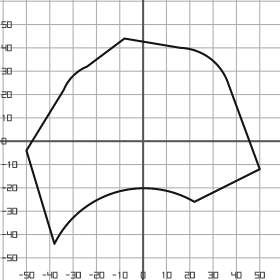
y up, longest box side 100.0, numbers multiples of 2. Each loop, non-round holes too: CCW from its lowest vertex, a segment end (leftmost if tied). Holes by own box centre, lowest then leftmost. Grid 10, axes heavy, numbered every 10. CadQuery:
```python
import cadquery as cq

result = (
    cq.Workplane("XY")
    .moveTo(-38.0, -44.0)
    .threePointArc((-12.0, -22.0), (22.0, -26.0))
    .lineTo(50.0, -12.0)
    .lineTo(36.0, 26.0)
    .threePointArc((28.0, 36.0), (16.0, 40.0))
    .lineTo(-8.0, 44.0)
    .lineTo(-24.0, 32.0)
    .threePointArc((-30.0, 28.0), (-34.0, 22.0))
    .lineTo(-50.0, -4.0)
    .close()
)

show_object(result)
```